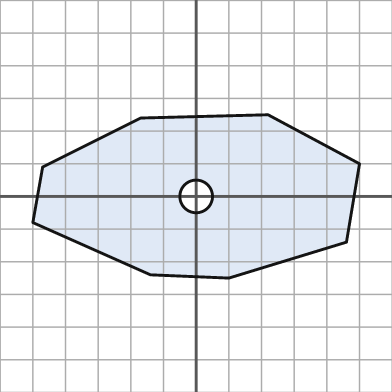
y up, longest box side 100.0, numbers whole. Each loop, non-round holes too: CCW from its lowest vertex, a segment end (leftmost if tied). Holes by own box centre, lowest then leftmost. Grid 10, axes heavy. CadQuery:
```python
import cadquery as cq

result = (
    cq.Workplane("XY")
    .moveTo(10.0, -25.0)
    .lineTo(46.0, -14.0)
    .lineTo(50.0, 10.0)
    .lineTo(22.0, 25.0)
    .lineTo(-17.0, 24.0)
    .lineTo(-47.0, 9.0)
    .lineTo(-50.0, -8.0)
    .lineTo(-14.0, -24.0)
    .close()
    .moveTo(0.0, 0.0)
    .circle(5.0)
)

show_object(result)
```